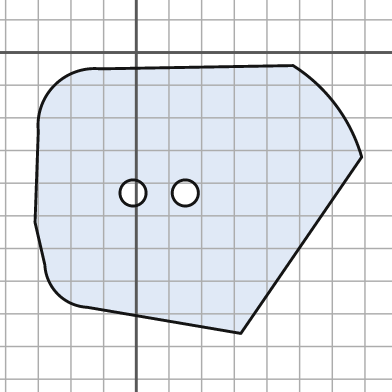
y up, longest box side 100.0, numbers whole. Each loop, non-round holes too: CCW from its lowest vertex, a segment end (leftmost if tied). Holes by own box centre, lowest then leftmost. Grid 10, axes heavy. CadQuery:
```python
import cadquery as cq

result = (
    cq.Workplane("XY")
    .moveTo(32.0, -86.0)
    .lineTo(69.0, -32.0)
    .threePointArc((61.0, -16.0), (48.0, -4.0))
    .lineTo(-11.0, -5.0)
    .threePointArc((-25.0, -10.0), (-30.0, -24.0))
    .lineTo(-31.0, -52.0)
    .lineTo(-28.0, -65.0)
    .threePointArc((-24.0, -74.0), (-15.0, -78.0))
    .close()
    .moveTo(-1.0, -43.0)
    .circle(4.0)
    .moveTo(15.0, -43.0)
    .circle(4.0)
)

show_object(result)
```